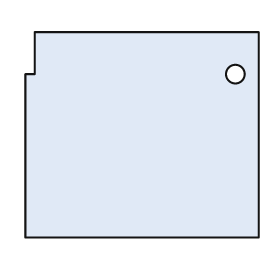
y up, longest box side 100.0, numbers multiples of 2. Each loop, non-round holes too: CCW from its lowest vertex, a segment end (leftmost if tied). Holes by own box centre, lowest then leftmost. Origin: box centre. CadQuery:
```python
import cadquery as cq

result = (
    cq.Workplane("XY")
    .moveTo(-50.0, -44.0)
    .lineTo(50.0, -44.0)
    .lineTo(50.0, 44.0)
    .lineTo(-46.0, 44.0)
    .lineTo(-46.0, 26.0)
    .lineTo(-50.0, 26.0)
    .close()
    .moveTo(40.0, 26.0)
    .circle(4.0)
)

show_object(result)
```